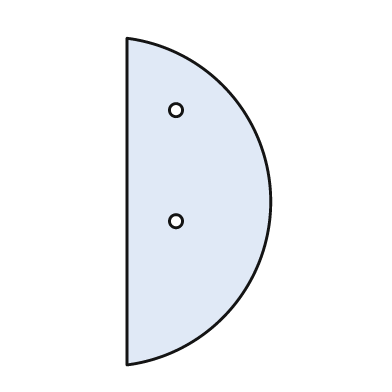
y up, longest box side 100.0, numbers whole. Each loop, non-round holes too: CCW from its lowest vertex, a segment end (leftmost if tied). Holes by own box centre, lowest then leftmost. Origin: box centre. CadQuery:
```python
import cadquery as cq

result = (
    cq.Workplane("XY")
    .moveTo(-22.0, -50.0)
    .threePointArc((22.0, 0.0), (-22.0, 50.0))
    .close()
    .moveTo(-7.0, -6.0)
    .circle(2.0)
    .moveTo(-7.0, 28.0)
    .circle(2.0)
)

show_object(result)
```